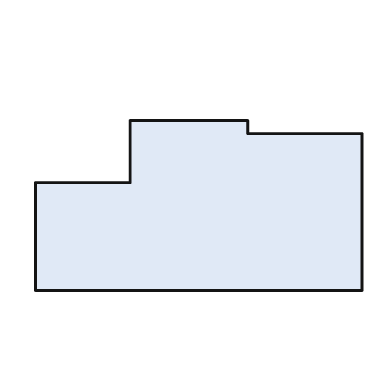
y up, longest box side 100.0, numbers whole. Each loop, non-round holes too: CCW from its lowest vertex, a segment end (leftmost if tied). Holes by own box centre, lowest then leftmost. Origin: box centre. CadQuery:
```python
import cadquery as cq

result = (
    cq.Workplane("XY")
    .moveTo(-50.0, -26.0)
    .lineTo(50.0, -26.0)
    .lineTo(50.0, 22.0)
    .lineTo(15.0, 22.0)
    .lineTo(15.0, 26.0)
    .lineTo(-21.0, 26.0)
    .lineTo(-21.0, 7.0)
    .lineTo(-50.0, 7.0)
    .close()
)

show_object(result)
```